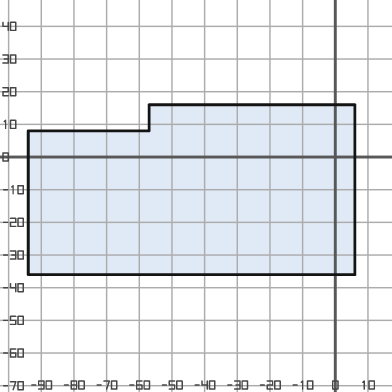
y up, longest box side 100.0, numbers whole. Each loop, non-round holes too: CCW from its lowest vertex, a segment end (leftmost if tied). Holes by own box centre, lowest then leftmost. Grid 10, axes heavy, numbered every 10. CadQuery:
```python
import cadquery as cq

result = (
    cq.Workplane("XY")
    .moveTo(-94.0, -36.0)
    .lineTo(6.0, -36.0)
    .lineTo(6.0, 16.0)
    .lineTo(-57.0, 16.0)
    .lineTo(-57.0, 8.0)
    .lineTo(-94.0, 8.0)
    .close()
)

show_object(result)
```